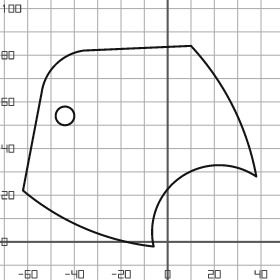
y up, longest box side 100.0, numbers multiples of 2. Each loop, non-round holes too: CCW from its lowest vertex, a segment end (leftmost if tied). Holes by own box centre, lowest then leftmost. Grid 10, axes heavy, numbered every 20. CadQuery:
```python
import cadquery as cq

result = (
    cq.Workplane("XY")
    .moveTo(-6.0, -2.0)
    .threePointArc((6.0, 28.0), (38.0, 28.0))
    .threePointArc((28.0, 58.0), (10.0, 84.0))
    .lineTo(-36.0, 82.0)
    .threePointArc((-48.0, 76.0), (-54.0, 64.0))
    .lineTo(-62.0, 22.0)
    .threePointArc((-36.0, 6.0), (-6.0, -2.0))
    .close()
    .moveTo(-44.0, 54.0)
    .circle(4.0)
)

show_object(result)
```